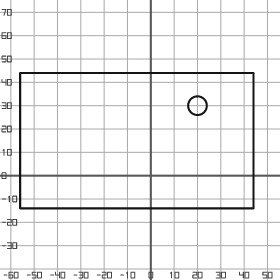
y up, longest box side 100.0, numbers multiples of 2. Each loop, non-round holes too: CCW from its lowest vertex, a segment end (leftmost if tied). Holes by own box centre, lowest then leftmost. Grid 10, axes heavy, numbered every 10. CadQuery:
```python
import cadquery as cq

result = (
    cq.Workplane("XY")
    .moveTo(-56.0, -14.0)
    .lineTo(44.0, -14.0)
    .lineTo(44.0, 44.0)
    .lineTo(-56.0, 44.0)
    .close()
    .moveTo(20.0, 30.0)
    .circle(4.0)
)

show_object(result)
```